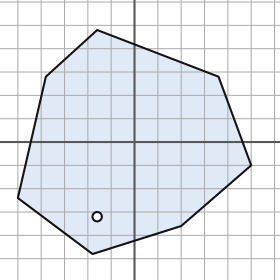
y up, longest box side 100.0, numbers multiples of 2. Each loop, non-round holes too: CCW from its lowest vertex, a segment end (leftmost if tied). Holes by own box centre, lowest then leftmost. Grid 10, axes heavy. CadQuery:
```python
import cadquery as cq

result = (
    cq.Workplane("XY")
    .moveTo(-18.0, -48.0)
    .lineTo(20.0, -36.0)
    .lineTo(50.0, -10.0)
    .lineTo(36.0, 28.0)
    .lineTo(-16.0, 48.0)
    .lineTo(-38.0, 28.0)
    .lineTo(-50.0, -24.0)
    .close()
    .moveTo(-16.0, -32.0)
    .circle(2.0)
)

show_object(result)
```